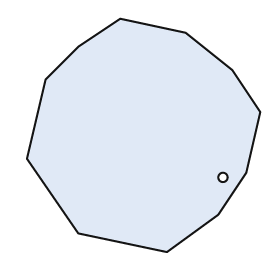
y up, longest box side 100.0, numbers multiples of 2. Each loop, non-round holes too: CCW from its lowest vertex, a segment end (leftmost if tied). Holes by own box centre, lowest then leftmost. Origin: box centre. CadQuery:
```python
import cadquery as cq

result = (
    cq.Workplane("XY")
    .moveTo(10.0, -50.0)
    .lineTo(32.0, -34.0)
    .lineTo(44.0, -16.0)
    .lineTo(50.0, 10.0)
    .lineTo(38.0, 28.0)
    .lineTo(18.0, 44.0)
    .lineTo(-10.0, 50.0)
    .lineTo(-28.0, 38.0)
    .lineTo(-42.0, 24.0)
    .lineTo(-50.0, -10.0)
    .lineTo(-28.0, -42.0)
    .close()
    .moveTo(34.0, -18.0)
    .circle(2.0)
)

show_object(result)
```